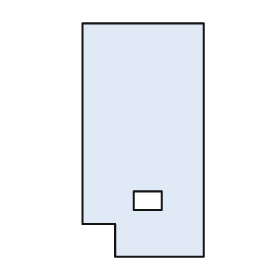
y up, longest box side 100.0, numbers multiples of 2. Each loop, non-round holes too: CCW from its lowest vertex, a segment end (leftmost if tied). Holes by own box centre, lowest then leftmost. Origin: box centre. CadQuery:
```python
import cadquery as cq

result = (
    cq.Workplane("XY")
    .moveTo(-12.0, -50.0)
    .lineTo(26.0, -50.0)
    .lineTo(26.0, 50.0)
    .lineTo(-26.0, 50.0)
    .lineTo(-26.0, -36.0)
    .lineTo(-12.0, -36.0)
    .close()
    .moveTo(-4.0, -30.0)
    .lineTo(8.0, -30.0)
    .lineTo(8.0, -22.0)
    .lineTo(-4.0, -22.0)
    .close()
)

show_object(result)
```